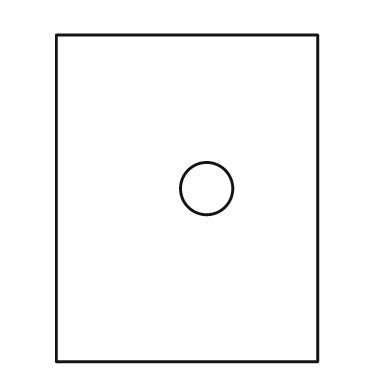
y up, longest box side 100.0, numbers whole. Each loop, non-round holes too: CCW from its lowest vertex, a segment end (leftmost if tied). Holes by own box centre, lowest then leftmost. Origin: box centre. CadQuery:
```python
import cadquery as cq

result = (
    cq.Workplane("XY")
    .moveTo(-40.0, -50.0)
    .lineTo(40.0, -50.0)
    .lineTo(40.0, 50.0)
    .lineTo(-40.0, 50.0)
    .close()
    .moveTo(6.0, 3.0)
    .circle(8.0)
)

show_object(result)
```